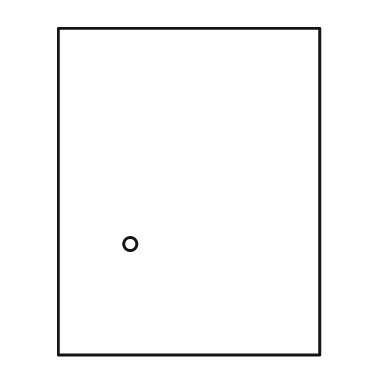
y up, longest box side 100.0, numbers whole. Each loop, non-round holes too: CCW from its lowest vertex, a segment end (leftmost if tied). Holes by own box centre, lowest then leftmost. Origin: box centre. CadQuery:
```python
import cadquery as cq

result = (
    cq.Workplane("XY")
    .moveTo(-40.0, -50.0)
    .lineTo(40.0, -50.0)
    .lineTo(40.0, 50.0)
    .lineTo(-40.0, 50.0)
    .close()
    .moveTo(-18.0, -16.0)
    .circle(2.0)
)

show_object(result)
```